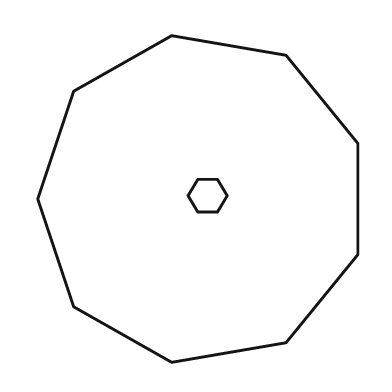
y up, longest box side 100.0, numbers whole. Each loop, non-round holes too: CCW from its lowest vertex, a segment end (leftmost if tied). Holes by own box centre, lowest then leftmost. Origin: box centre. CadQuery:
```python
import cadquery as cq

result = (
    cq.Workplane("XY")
    .moveTo(-8.0, -50.0)
    .lineTo(27.0, -44.0)
    .lineTo(49.0, -17.0)
    .lineTo(49.0, 17.0)
    .lineTo(27.0, 44.0)
    .lineTo(-8.0, 50.0)
    .lineTo(-38.0, 33.0)
    .lineTo(-49.0, 0.0)
    .lineTo(-38.0, -33.0)
    .close()
    .moveTo(0.0, -4.0)
    .lineTo(6.0, -4.0)
    .lineTo(9.0, 1.0)
    .lineTo(6.0, 6.0)
    .lineTo(0.0, 6.0)
    .lineTo(-3.0, 1.0)
    .close()
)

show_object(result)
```